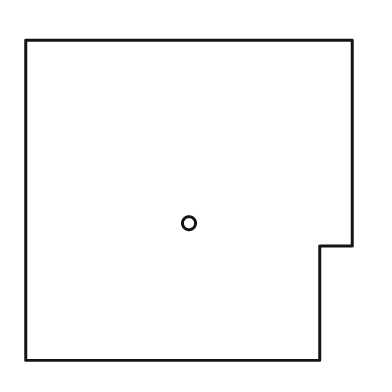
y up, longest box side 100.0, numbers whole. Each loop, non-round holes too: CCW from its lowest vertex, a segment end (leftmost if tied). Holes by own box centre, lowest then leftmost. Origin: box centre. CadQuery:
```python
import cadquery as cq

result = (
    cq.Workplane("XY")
    .moveTo(-50.0, -49.0)
    .lineTo(40.0, -49.0)
    .lineTo(40.0, -14.0)
    .lineTo(50.0, -14.0)
    .lineTo(50.0, 49.0)
    .lineTo(-50.0, 49.0)
    .close()
    .moveTo(0.0, -7.0)
    .circle(2.0)
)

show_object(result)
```